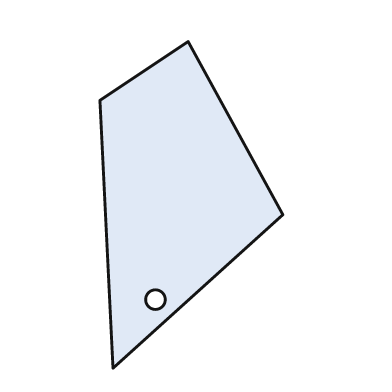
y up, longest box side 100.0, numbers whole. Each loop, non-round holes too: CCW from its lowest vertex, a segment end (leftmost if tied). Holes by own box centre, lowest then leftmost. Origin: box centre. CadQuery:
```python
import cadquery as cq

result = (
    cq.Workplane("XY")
    .moveTo(-24.0, -50.0)
    .lineTo(28.0, -3.0)
    .lineTo(-1.0, 50.0)
    .lineTo(-28.0, 32.0)
    .close()
    .moveTo(-11.0, -29.0)
    .circle(3.0)
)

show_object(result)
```